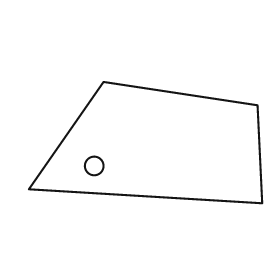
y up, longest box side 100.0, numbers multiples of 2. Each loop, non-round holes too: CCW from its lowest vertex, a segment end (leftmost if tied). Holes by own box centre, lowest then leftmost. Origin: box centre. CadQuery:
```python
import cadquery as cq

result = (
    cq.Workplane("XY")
    .moveTo(50.0, -26.0)
    .lineTo(48.0, 16.0)
    .lineTo(-18.0, 26.0)
    .lineTo(-50.0, -20.0)
    .close()
    .moveTo(-22.0, -10.0)
    .circle(4.0)
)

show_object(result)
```